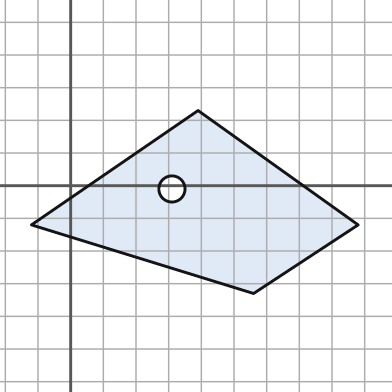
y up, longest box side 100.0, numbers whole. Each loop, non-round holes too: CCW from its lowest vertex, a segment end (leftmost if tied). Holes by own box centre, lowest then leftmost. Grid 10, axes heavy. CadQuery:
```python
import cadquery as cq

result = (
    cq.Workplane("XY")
    .moveTo(56.0, -33.0)
    .lineTo(88.0, -12.0)
    .lineTo(39.0, 23.0)
    .lineTo(-12.0, -12.0)
    .close()
    .moveTo(31.0, -1.0)
    .circle(4.0)
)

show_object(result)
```